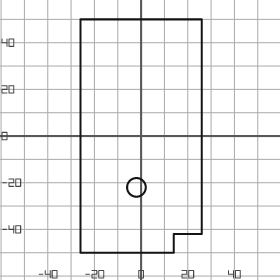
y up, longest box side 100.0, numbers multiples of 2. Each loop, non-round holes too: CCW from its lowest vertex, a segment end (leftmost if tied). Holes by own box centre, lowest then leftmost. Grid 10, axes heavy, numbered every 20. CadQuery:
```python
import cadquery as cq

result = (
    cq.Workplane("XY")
    .moveTo(-26.0, -50.0)
    .lineTo(14.0, -50.0)
    .lineTo(14.0, -42.0)
    .lineTo(26.0, -42.0)
    .lineTo(26.0, 50.0)
    .lineTo(-26.0, 50.0)
    .close()
    .moveTo(-2.0, -22.0)
    .circle(4.0)
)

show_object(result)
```